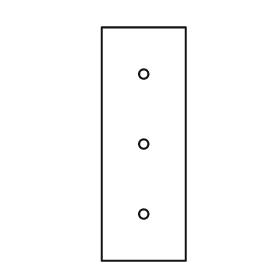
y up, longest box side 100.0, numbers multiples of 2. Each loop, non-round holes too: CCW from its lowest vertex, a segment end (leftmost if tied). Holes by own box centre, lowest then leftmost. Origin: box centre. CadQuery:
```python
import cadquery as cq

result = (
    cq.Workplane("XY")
    .moveTo(-18.0, -50.0)
    .lineTo(18.0, -50.0)
    .lineTo(18.0, 50.0)
    .lineTo(-18.0, 50.0)
    .close()
    .moveTo(0.0, -30.0)
    .circle(2.0)
    .moveTo(0.0, 0.0)
    .circle(2.0)
    .moveTo(0.0, 30.0)
    .circle(2.0)
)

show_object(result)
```